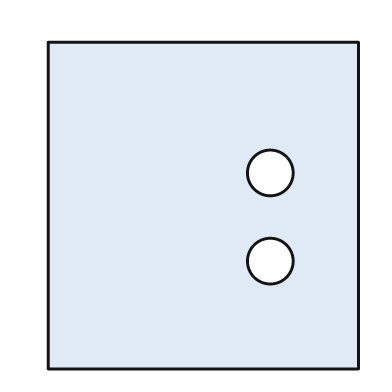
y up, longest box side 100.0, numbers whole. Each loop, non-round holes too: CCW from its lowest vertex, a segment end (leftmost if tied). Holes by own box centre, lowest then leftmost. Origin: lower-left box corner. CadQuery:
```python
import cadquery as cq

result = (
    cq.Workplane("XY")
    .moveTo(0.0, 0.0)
    .lineTo(95.0, 0.0)
    .lineTo(95.0, 100.0)
    .lineTo(0.0, 100.0)
    .close()
    .moveTo(68.0, 33.0)
    .circle(7.0)
    .moveTo(68.0, 60.0)
    .circle(7.0)
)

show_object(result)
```